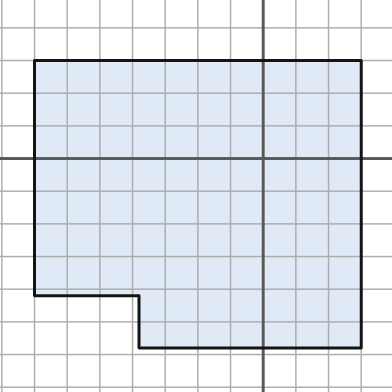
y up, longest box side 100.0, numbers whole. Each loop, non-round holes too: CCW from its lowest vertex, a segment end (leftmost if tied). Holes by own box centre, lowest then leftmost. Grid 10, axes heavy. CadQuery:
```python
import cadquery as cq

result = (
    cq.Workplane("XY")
    .moveTo(-38.0, -58.0)
    .lineTo(30.0, -58.0)
    .lineTo(30.0, 30.0)
    .lineTo(-70.0, 30.0)
    .lineTo(-70.0, -42.0)
    .lineTo(-38.0, -42.0)
    .close()
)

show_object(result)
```